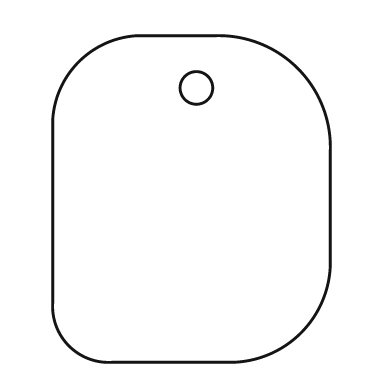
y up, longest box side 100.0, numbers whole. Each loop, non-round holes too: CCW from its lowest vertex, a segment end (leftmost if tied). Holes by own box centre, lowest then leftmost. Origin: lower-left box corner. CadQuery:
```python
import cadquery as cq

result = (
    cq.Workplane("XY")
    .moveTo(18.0, 0.0)
    .lineTo(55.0, 0.0)
    .threePointArc((76.0, 9.0), (85.0, 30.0))
    .lineTo(85.0, 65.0)
    .threePointArc((75.0, 90.0), (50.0, 100.0))
    .lineTo(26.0, 100.0)
    .threePointArc((8.0, 92.0), (0.0, 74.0))
    .lineTo(0.0, 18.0)
    .threePointArc((5.0, 5.0), (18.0, 0.0))
    .close()
    .moveTo(44.0, 84.0)
    .circle(5.0)
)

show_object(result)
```